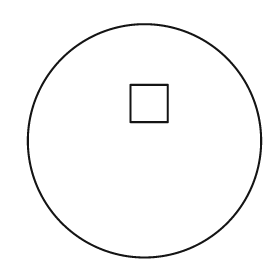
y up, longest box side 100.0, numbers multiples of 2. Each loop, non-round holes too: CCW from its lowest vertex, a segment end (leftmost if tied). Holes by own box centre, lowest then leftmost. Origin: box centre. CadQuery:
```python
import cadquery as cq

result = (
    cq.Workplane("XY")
    .moveTo(0.0, 0.0)
    .circle(50.0)
    .moveTo(-6.0, 8.0)
    .lineTo(10.0, 8.0)
    .lineTo(10.0, 24.0)
    .lineTo(-6.0, 24.0)
    .close()
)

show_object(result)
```